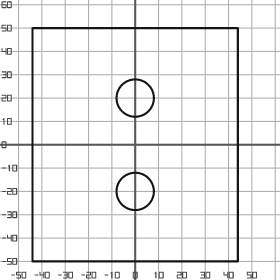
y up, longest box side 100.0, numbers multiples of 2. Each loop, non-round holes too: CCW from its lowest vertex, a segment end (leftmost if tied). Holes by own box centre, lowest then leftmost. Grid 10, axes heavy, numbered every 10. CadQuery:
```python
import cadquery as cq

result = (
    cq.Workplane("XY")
    .moveTo(-44.0, -50.0)
    .lineTo(44.0, -50.0)
    .lineTo(44.0, 50.0)
    .lineTo(-44.0, 50.0)
    .close()
    .moveTo(0.0, -20.0)
    .circle(8.0)
    .moveTo(0.0, 20.0)
    .circle(8.0)
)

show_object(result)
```